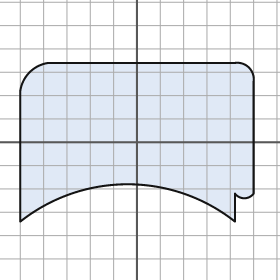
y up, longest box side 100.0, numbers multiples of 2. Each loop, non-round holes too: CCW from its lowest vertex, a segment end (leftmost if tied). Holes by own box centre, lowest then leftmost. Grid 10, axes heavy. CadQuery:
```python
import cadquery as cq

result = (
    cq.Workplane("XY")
    .moveTo(-50.0, -34.0)
    .threePointArc((-4.0, -18.0), (42.0, -34.0))
    .lineTo(42.0, -22.0)
    .threePointArc((46.0, -24.0), (50.0, -22.0))
    .lineTo(50.0, 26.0)
    .threePointArc((48.0, 32.0), (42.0, 34.0))
    .lineTo(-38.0, 34.0)
    .threePointArc((-46.0, 30.0), (-50.0, 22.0))
    .close()
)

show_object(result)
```